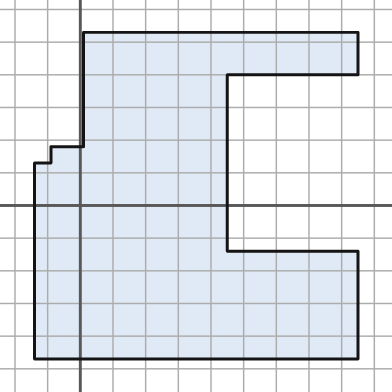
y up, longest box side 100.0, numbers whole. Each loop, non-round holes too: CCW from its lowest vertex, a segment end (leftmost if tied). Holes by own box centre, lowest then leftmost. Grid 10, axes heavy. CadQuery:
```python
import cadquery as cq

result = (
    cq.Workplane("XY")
    .moveTo(-14.0, -47.0)
    .lineTo(85.0, -47.0)
    .lineTo(85.0, -14.0)
    .lineTo(45.0, -14.0)
    .lineTo(45.0, 40.0)
    .lineTo(85.0, 40.0)
    .lineTo(85.0, 53.0)
    .lineTo(1.0, 53.0)
    .lineTo(1.0, 18.0)
    .lineTo(-9.0, 18.0)
    .lineTo(-9.0, 13.0)
    .lineTo(-14.0, 13.0)
    .close()
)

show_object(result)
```